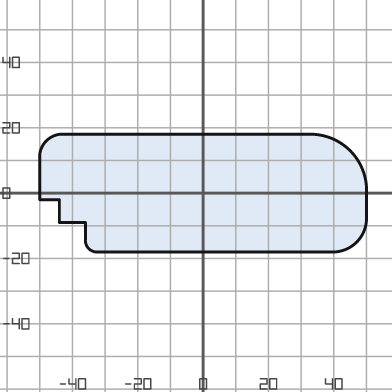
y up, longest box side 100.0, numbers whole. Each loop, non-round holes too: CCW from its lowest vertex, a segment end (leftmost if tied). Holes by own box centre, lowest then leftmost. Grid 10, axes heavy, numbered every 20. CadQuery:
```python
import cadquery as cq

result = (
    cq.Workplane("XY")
    .moveTo(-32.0, -18.0)
    .lineTo(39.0, -18.0)
    .threePointArc((47.0, -15.0), (50.0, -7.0))
    .lineTo(50.0, 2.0)
    .threePointArc((45.0, 13.0), (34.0, 18.0))
    .lineTo(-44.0, 18.0)
    .threePointArc((-48.0, 16.0), (-50.0, 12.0))
    .lineTo(-50.0, -2.0)
    .lineTo(-44.0, -2.0)
    .lineTo(-44.0, -9.0)
    .lineTo(-36.0, -9.0)
    .lineTo(-36.0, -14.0)
    .threePointArc((-35.0, -17.0), (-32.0, -18.0))
    .close()
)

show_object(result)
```